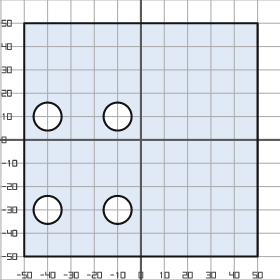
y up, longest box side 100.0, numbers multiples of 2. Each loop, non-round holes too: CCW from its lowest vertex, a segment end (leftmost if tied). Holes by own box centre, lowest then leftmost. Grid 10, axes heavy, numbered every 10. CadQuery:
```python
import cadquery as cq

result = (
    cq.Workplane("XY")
    .moveTo(-50.0, -50.0)
    .lineTo(50.0, -50.0)
    .lineTo(50.0, 50.0)
    .lineTo(-50.0, 50.0)
    .close()
    .moveTo(-40.0, -30.0)
    .circle(6.0)
    .moveTo(-10.0, -30.0)
    .circle(6.0)
    .moveTo(-40.0, 10.0)
    .circle(6.0)
    .moveTo(-10.0, 10.0)
    .circle(6.0)
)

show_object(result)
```